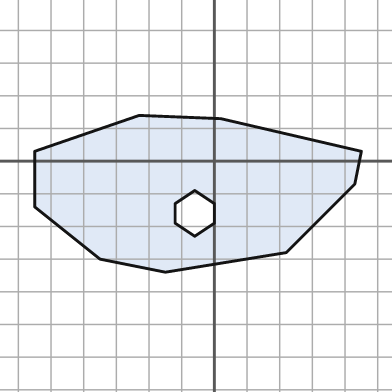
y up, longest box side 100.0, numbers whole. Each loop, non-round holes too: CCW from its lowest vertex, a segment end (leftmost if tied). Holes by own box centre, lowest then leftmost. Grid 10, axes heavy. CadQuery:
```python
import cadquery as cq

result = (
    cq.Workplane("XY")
    .moveTo(-15.0, -34.0)
    .lineTo(22.0, -28.0)
    .lineTo(43.0, -7.0)
    .lineTo(45.0, 3.0)
    .lineTo(2.0, 13.0)
    .lineTo(-23.0, 14.0)
    .lineTo(-55.0, 3.0)
    .lineTo(-55.0, -14.0)
    .lineTo(-35.0, -30.0)
    .close()
    .moveTo(-6.0, -23.0)
    .lineTo(0.0, -19.0)
    .lineTo(0.0, -13.0)
    .lineTo(-6.0, -9.0)
    .lineTo(-12.0, -13.0)
    .lineTo(-12.0, -19.0)
    .close()
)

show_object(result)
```